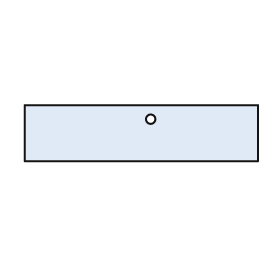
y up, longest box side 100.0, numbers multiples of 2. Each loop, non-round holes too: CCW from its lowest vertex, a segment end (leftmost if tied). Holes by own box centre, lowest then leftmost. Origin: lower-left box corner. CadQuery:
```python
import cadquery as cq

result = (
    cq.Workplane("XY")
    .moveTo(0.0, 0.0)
    .lineTo(100.0, 0.0)
    .lineTo(100.0, 24.0)
    .lineTo(0.0, 24.0)
    .close()
    .moveTo(54.0, 18.0)
    .circle(2.0)
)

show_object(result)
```